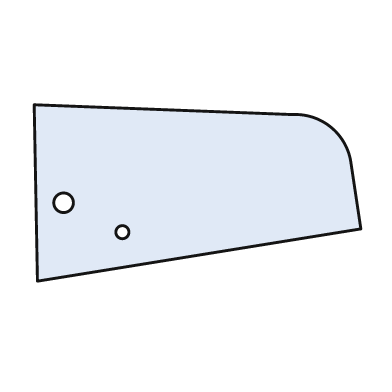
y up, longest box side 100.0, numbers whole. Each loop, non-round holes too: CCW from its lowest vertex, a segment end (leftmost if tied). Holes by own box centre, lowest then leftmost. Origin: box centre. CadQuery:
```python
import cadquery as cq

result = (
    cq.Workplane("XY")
    .moveTo(-49.0, -27.0)
    .lineTo(50.0, -11.0)
    .lineTo(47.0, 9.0)
    .threePointArc((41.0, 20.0), (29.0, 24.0))
    .lineTo(-50.0, 27.0)
    .close()
    .moveTo(-23.0, -12.0)
    .circle(2.0)
    .moveTo(-41.0, -3.0)
    .circle(3.0)
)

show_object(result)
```